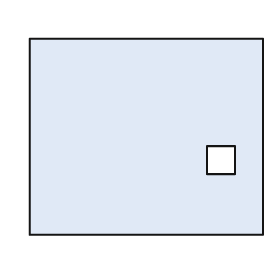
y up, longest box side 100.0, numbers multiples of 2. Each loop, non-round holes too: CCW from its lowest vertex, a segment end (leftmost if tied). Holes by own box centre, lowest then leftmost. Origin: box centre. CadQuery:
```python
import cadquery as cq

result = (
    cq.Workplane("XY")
    .moveTo(-50.0, -42.0)
    .lineTo(50.0, -42.0)
    .lineTo(50.0, 42.0)
    .lineTo(-50.0, 42.0)
    .close()
    .moveTo(26.0, -16.0)
    .lineTo(38.0, -16.0)
    .lineTo(38.0, -4.0)
    .lineTo(26.0, -4.0)
    .close()
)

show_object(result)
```